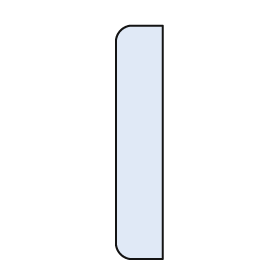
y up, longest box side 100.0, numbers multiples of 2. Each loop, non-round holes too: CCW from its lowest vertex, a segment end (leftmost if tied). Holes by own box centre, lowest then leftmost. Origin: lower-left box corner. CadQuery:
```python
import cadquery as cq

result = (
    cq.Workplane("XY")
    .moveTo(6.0, 0.0)
    .lineTo(20.0, 0.0)
    .lineTo(20.0, 100.0)
    .lineTo(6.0, 100.0)
    .threePointArc((2.0, 98.0), (0.0, 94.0))
    .lineTo(0.0, 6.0)
    .threePointArc((2.0, 2.0), (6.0, 0.0))
    .close()
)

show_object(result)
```